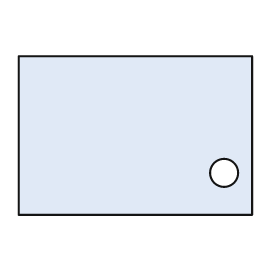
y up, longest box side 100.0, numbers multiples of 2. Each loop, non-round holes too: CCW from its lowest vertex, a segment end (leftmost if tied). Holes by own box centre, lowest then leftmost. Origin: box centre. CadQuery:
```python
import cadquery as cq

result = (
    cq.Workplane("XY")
    .moveTo(-50.0, -34.0)
    .lineTo(50.0, -34.0)
    .lineTo(50.0, 34.0)
    .lineTo(-50.0, 34.0)
    .close()
    .moveTo(38.0, -16.0)
    .circle(6.0)
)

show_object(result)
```